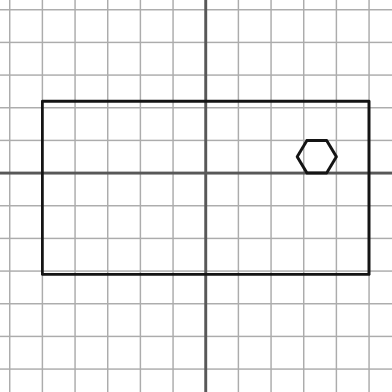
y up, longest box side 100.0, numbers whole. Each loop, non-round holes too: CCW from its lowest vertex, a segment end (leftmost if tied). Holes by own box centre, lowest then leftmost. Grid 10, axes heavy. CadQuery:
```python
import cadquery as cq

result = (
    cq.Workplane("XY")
    .moveTo(-50.0, -31.0)
    .lineTo(50.0, -31.0)
    .lineTo(50.0, 22.0)
    .lineTo(-50.0, 22.0)
    .close()
    .moveTo(31.0, 0.0)
    .lineTo(37.0, 0.0)
    .lineTo(40.0, 5.0)
    .lineTo(37.0, 10.0)
    .lineTo(31.0, 10.0)
    .lineTo(28.0, 5.0)
    .close()
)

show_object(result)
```